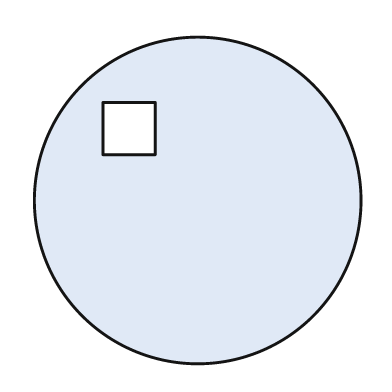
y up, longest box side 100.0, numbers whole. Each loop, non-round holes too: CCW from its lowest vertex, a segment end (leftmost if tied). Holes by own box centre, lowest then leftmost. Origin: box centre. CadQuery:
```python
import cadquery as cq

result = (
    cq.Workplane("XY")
    .moveTo(0.0, 0.0)
    .circle(50.0)
    .moveTo(-29.0, 14.0)
    .lineTo(-13.0, 14.0)
    .lineTo(-13.0, 30.0)
    .lineTo(-29.0, 30.0)
    .close()
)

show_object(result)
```